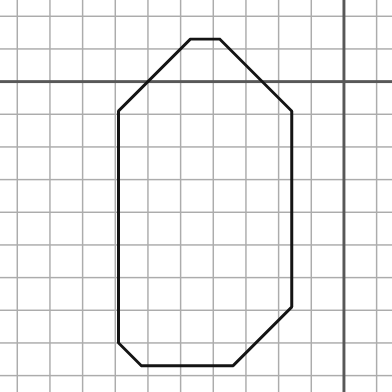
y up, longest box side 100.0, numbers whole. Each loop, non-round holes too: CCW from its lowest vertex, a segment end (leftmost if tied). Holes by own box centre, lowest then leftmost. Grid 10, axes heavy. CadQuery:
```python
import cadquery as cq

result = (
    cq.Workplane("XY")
    .moveTo(-62.0, -87.0)
    .lineTo(-34.0, -87.0)
    .lineTo(-16.0, -69.0)
    .lineTo(-16.0, -9.0)
    .lineTo(-38.0, 13.0)
    .lineTo(-47.0, 13.0)
    .lineTo(-69.0, -9.0)
    .lineTo(-69.0, -80.0)
    .close()
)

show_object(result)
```